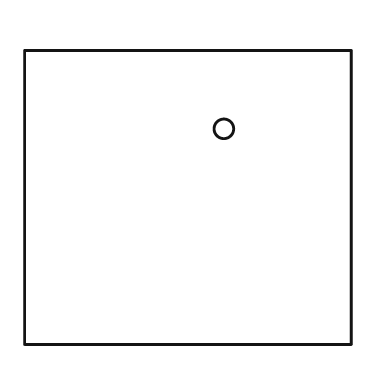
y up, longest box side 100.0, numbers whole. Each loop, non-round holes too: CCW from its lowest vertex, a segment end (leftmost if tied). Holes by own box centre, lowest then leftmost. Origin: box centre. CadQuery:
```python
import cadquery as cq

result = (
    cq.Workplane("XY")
    .moveTo(-50.0, -45.0)
    .lineTo(50.0, -45.0)
    .lineTo(50.0, 45.0)
    .lineTo(-50.0, 45.0)
    .close()
    .moveTo(11.0, 21.0)
    .circle(3.0)
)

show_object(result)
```